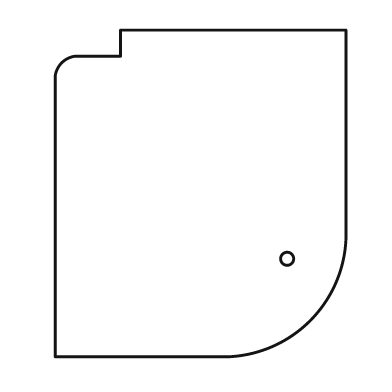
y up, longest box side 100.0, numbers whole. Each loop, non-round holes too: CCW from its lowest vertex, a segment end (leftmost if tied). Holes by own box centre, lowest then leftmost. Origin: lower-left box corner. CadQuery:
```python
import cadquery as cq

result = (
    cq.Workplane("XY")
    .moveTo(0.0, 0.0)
    .lineTo(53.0, 0.0)
    .threePointArc((78.0, 11.0), (89.0, 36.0))
    .lineTo(89.0, 100.0)
    .lineTo(20.0, 100.0)
    .lineTo(20.0, 92.0)
    .lineTo(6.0, 92.0)
    .threePointArc((2.0, 90.0), (0.0, 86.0))
    .close()
    .moveTo(71.0, 30.0)
    .circle(2.0)
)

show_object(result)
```